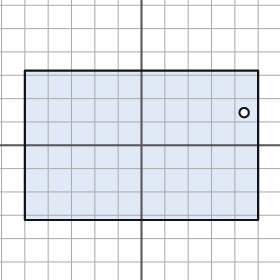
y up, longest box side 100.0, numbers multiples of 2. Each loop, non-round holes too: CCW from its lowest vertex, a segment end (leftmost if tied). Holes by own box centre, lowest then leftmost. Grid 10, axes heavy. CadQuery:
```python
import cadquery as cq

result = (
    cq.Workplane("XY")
    .moveTo(-50.0, -32.0)
    .lineTo(50.0, -32.0)
    .lineTo(50.0, 32.0)
    .lineTo(-50.0, 32.0)
    .close()
    .moveTo(44.0, 14.0)
    .circle(2.0)
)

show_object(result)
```